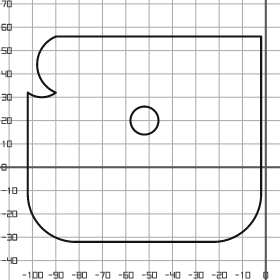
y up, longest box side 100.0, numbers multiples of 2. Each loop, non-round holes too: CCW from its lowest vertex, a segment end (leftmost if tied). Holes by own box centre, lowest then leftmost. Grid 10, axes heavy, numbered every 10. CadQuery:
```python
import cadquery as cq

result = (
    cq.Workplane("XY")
    .moveTo(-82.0, -32.0)
    .lineTo(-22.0, -32.0)
    .threePointArc((-8.0, -26.0), (-2.0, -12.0))
    .lineTo(-2.0, 56.0)
    .lineTo(-90.0, 56.0)
    .threePointArc((-98.0, 44.0), (-90.0, 32.0))
    .threePointArc((-96.0, 30.0), (-102.0, 32.0))
    .lineTo(-102.0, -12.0)
    .threePointArc((-96.0, -26.0), (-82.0, -32.0))
    .close()
    .moveTo(-52.0, 20.0)
    .circle(6.0)
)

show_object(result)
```